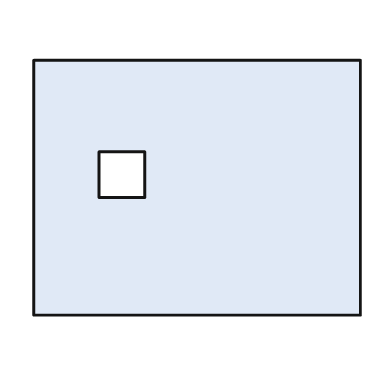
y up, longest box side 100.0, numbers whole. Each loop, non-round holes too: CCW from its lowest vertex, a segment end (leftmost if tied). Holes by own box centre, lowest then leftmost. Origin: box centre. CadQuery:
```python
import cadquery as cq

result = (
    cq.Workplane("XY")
    .moveTo(-50.0, -39.0)
    .lineTo(50.0, -39.0)
    .lineTo(50.0, 39.0)
    .lineTo(-50.0, 39.0)
    .close()
    .moveTo(-30.0, -3.0)
    .lineTo(-16.0, -3.0)
    .lineTo(-16.0, 11.0)
    .lineTo(-30.0, 11.0)
    .close()
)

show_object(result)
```